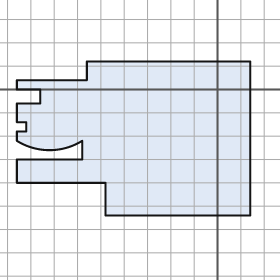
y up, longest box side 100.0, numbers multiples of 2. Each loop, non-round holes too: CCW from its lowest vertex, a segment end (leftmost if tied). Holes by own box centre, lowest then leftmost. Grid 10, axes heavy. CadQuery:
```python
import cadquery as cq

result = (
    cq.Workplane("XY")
    .moveTo(-48.0, -54.0)
    .lineTo(14.0, -54.0)
    .lineTo(14.0, 12.0)
    .lineTo(-56.0, 12.0)
    .lineTo(-56.0, 4.0)
    .lineTo(-86.0, 4.0)
    .lineTo(-86.0, 0.0)
    .lineTo(-76.0, 0.0)
    .lineTo(-76.0, -6.0)
    .lineTo(-86.0, -6.0)
    .lineTo(-86.0, -14.0)
    .lineTo(-82.0, -14.0)
    .lineTo(-82.0, -18.0)
    .lineTo(-86.0, -18.0)
    .lineTo(-86.0, -22.0)
    .threePointArc((-72.0, -26.0), (-58.0, -22.0))
    .lineTo(-58.0, -30.0)
    .lineTo(-86.0, -30.0)
    .lineTo(-86.0, -40.0)
    .lineTo(-48.0, -40.0)
    .close()
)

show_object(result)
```